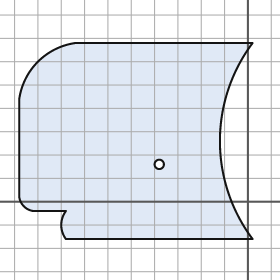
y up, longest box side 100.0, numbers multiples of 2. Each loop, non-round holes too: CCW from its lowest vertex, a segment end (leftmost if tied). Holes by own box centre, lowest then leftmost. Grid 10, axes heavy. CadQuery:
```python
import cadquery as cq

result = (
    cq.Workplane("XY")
    .moveTo(-78.0, -16.0)
    .lineTo(2.0, -16.0)
    .threePointArc((-12.0, 26.0), (2.0, 68.0))
    .lineTo(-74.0, 68.0)
    .threePointArc((-90.0, 60.0), (-98.0, 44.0))
    .lineTo(-98.0, 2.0)
    .threePointArc((-96.0, -2.0), (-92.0, -4.0))
    .lineTo(-78.0, -4.0)
    .threePointArc((-80.0, -10.0), (-78.0, -16.0))
    .close()
    .moveTo(-38.0, 16.0)
    .circle(2.0)
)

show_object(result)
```